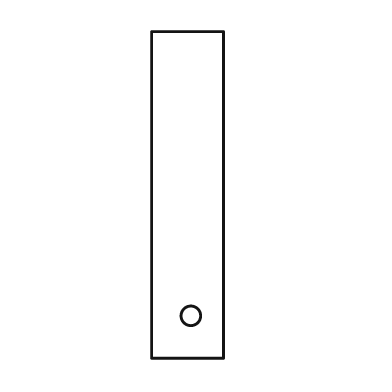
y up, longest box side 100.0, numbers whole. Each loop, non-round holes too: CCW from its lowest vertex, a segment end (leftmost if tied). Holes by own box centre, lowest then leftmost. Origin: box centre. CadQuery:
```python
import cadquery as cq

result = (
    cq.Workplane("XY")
    .moveTo(-11.0, -50.0)
    .lineTo(11.0, -50.0)
    .lineTo(11.0, 50.0)
    .lineTo(-11.0, 50.0)
    .close()
    .moveTo(1.0, -37.0)
    .circle(3.0)
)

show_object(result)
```